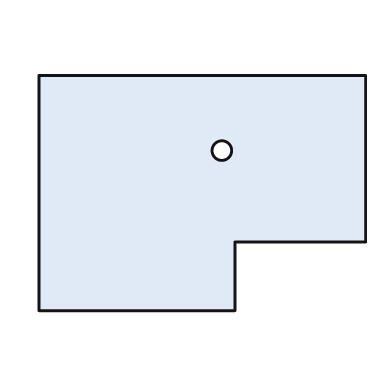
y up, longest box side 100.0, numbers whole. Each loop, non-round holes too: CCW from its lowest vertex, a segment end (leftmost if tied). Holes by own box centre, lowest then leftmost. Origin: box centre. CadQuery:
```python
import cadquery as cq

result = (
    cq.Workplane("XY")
    .moveTo(-50.0, -36.0)
    .lineTo(10.0, -36.0)
    .lineTo(10.0, -15.0)
    .lineTo(50.0, -15.0)
    .lineTo(50.0, 36.0)
    .lineTo(-50.0, 36.0)
    .close()
    .moveTo(6.0, 13.0)
    .circle(3.0)
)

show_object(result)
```